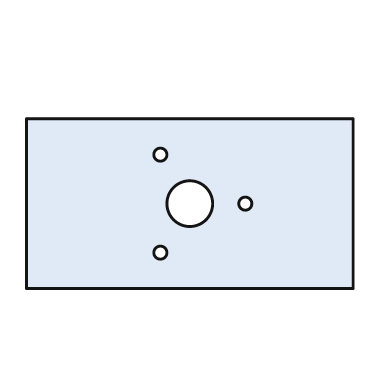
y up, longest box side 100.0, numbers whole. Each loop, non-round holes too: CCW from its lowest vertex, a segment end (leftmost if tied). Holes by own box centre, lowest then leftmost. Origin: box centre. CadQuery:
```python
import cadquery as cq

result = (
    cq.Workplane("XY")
    .moveTo(-50.0, -26.0)
    .lineTo(50.0, -26.0)
    .lineTo(50.0, 26.0)
    .lineTo(-50.0, 26.0)
    .close()
    .moveTo(-9.0, -15.0)
    .circle(2.0)
    .moveTo(0.0, 0.0)
    .circle(7.0)
    .moveTo(17.0, 0.0)
    .circle(2.0)
    .moveTo(-9.0, 15.0)
    .circle(2.0)
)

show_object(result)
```